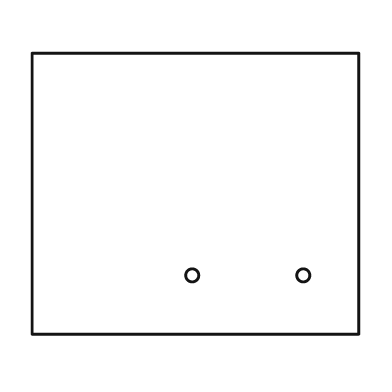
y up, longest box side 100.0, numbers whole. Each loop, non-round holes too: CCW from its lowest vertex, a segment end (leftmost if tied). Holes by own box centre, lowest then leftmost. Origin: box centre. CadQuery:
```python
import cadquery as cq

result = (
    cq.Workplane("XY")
    .moveTo(-50.0, -43.0)
    .lineTo(50.0, -43.0)
    .lineTo(50.0, 43.0)
    .lineTo(-50.0, 43.0)
    .close()
    .moveTo(-1.0, -25.0)
    .circle(2.0)
    .moveTo(33.0, -25.0)
    .circle(2.0)
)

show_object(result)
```